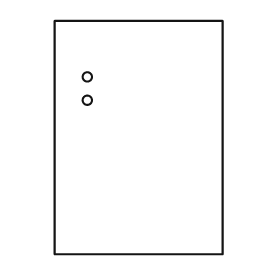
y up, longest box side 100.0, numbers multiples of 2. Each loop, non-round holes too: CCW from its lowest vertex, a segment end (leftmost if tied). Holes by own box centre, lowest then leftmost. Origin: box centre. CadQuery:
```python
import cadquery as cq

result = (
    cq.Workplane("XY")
    .moveTo(-36.0, -50.0)
    .lineTo(36.0, -50.0)
    .lineTo(36.0, 50.0)
    .lineTo(-36.0, 50.0)
    .close()
    .moveTo(-22.0, 16.0)
    .circle(2.0)
    .moveTo(-22.0, 26.0)
    .circle(2.0)
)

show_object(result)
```